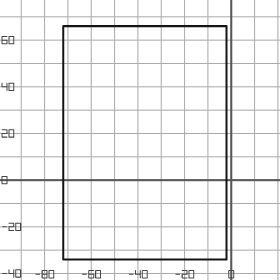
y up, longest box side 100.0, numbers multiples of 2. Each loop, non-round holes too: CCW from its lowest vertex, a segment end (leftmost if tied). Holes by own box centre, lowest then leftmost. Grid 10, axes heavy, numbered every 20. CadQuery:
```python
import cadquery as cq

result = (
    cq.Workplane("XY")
    .moveTo(-72.0, -34.0)
    .lineTo(-2.0, -34.0)
    .lineTo(-2.0, 66.0)
    .lineTo(-72.0, 66.0)
    .close()
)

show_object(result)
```